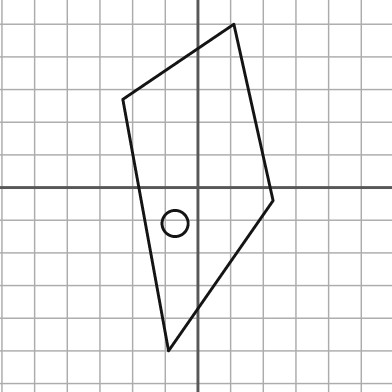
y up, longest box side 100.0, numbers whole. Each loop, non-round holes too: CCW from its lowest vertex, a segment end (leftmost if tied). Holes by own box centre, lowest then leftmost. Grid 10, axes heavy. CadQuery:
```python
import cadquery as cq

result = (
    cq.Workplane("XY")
    .moveTo(-9.0, -50.0)
    .lineTo(23.0, -4.0)
    .lineTo(11.0, 50.0)
    .lineTo(-23.0, 27.0)
    .close()
    .moveTo(-7.0, -11.0)
    .circle(4.0)
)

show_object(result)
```